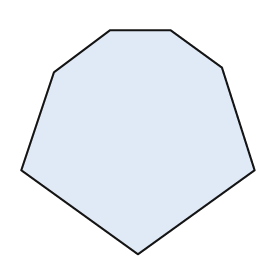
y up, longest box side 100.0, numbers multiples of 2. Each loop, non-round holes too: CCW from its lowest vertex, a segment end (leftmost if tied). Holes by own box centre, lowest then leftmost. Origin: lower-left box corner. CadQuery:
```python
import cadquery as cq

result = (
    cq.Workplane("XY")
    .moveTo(50.0, 0.0)
    .lineTo(100.0, 36.0)
    .lineTo(86.0, 80.0)
    .lineTo(64.0, 96.0)
    .lineTo(38.0, 96.0)
    .lineTo(14.0, 78.0)
    .lineTo(0.0, 36.0)
    .close()
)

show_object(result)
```